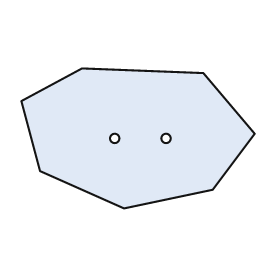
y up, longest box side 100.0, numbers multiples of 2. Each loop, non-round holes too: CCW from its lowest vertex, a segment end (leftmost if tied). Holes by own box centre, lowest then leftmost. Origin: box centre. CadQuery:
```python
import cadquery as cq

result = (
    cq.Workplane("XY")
    .moveTo(-6.0, -30.0)
    .lineTo(32.0, -22.0)
    .lineTo(50.0, 2.0)
    .lineTo(28.0, 28.0)
    .lineTo(-24.0, 30.0)
    .lineTo(-50.0, 16.0)
    .lineTo(-42.0, -14.0)
    .close()
    .moveTo(-10.0, 0.0)
    .circle(2.0)
    .moveTo(12.0, 0.0)
    .circle(2.0)
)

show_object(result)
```